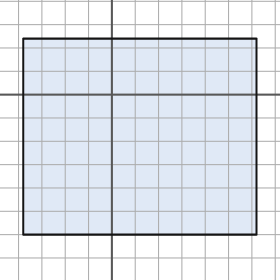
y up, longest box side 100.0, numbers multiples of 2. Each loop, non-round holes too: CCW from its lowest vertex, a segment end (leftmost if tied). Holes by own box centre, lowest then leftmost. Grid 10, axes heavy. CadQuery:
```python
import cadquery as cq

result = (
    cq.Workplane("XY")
    .moveTo(-38.0, -60.0)
    .lineTo(62.0, -60.0)
    .lineTo(62.0, 24.0)
    .lineTo(-38.0, 24.0)
    .close()
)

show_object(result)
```